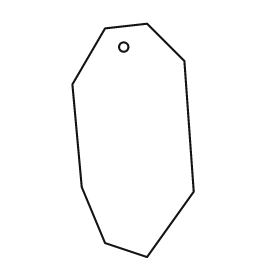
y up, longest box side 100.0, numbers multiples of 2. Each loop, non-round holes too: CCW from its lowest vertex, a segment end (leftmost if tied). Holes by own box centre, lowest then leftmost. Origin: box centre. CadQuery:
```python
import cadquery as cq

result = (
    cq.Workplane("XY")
    .moveTo(6.0, -50.0)
    .lineTo(26.0, -22.0)
    .lineTo(22.0, 34.0)
    .lineTo(6.0, 50.0)
    .lineTo(-12.0, 48.0)
    .lineTo(-26.0, 24.0)
    .lineTo(-22.0, -20.0)
    .lineTo(-12.0, -44.0)
    .close()
    .moveTo(-4.0, 40.0)
    .circle(2.0)
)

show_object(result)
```